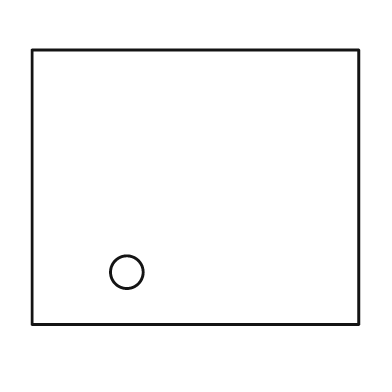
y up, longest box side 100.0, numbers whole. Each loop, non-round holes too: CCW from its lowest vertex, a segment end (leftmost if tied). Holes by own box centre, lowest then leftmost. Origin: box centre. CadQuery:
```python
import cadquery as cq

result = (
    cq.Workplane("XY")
    .moveTo(-50.0, -42.0)
    .lineTo(50.0, -42.0)
    .lineTo(50.0, 42.0)
    .lineTo(-50.0, 42.0)
    .close()
    .moveTo(-21.0, -26.0)
    .circle(5.0)
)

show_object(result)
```